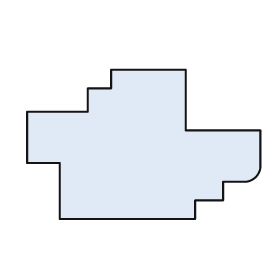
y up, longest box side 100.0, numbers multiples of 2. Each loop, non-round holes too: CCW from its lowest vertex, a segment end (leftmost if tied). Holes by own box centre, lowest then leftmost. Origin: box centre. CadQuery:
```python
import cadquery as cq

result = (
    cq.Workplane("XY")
    .moveTo(-36.0, -32.0)
    .lineTo(22.0, -32.0)
    .lineTo(22.0, -24.0)
    .lineTo(34.0, -24.0)
    .lineTo(34.0, -16.0)
    .lineTo(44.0, -16.0)
    .threePointArc((48.0, -14.0), (50.0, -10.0))
    .lineTo(50.0, 6.0)
    .lineTo(18.0, 6.0)
    .lineTo(18.0, 32.0)
    .lineTo(-14.0, 32.0)
    .lineTo(-14.0, 24.0)
    .lineTo(-24.0, 24.0)
    .lineTo(-24.0, 14.0)
    .lineTo(-50.0, 14.0)
    .lineTo(-50.0, -8.0)
    .lineTo(-36.0, -8.0)
    .close()
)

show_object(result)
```